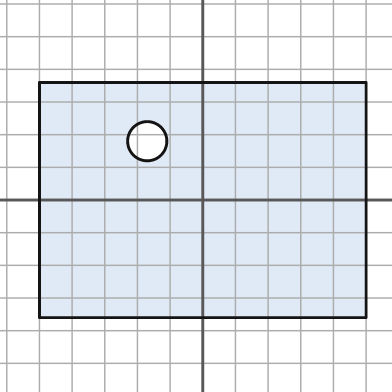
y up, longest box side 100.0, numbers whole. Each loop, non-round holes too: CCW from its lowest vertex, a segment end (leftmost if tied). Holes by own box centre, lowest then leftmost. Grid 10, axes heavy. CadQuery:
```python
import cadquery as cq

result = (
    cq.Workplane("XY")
    .moveTo(-50.0, -36.0)
    .lineTo(50.0, -36.0)
    .lineTo(50.0, 36.0)
    .lineTo(-50.0, 36.0)
    .close()
    .moveTo(-17.0, 18.0)
    .circle(6.0)
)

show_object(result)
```